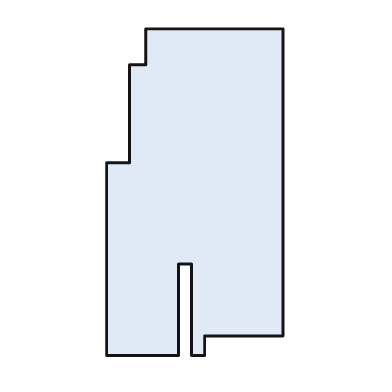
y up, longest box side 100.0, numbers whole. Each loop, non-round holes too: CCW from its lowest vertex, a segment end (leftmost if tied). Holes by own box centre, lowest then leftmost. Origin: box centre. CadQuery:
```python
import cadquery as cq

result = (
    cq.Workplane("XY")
    .moveTo(-27.0, -50.0)
    .lineTo(-5.0, -50.0)
    .lineTo(-5.0, -22.0)
    .lineTo(-1.0, -22.0)
    .lineTo(-1.0, -50.0)
    .lineTo(3.0, -50.0)
    .lineTo(3.0, -44.0)
    .lineTo(27.0, -44.0)
    .lineTo(27.0, 50.0)
    .lineTo(-15.0, 50.0)
    .lineTo(-15.0, 39.0)
    .lineTo(-20.0, 39.0)
    .lineTo(-20.0, 9.0)
    .lineTo(-27.0, 9.0)
    .close()
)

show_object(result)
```